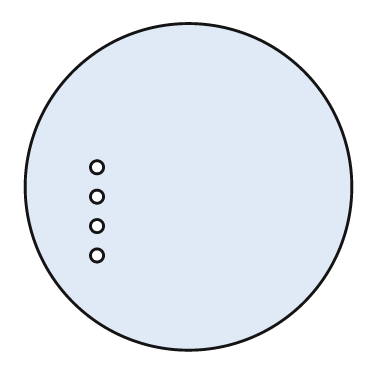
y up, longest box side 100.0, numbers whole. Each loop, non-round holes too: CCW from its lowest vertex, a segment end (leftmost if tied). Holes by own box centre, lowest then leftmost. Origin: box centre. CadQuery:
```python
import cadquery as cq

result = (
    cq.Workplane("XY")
    .moveTo(0.0, 0.0)
    .circle(50.0)
    .moveTo(-28.0, -21.0)
    .circle(2.0)
    .moveTo(-28.0, -12.0)
    .circle(2.0)
    .moveTo(-28.0, -3.0)
    .circle(2.0)
    .moveTo(-28.0, 6.0)
    .circle(2.0)
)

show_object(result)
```